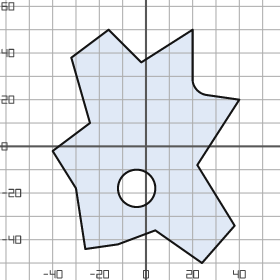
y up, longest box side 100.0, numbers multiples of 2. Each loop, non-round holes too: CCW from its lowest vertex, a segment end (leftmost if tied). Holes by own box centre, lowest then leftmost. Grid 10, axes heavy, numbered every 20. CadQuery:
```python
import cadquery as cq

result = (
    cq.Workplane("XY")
    .moveTo(24.0, -50.0)
    .lineTo(38.0, -34.0)
    .lineTo(22.0, -8.0)
    .lineTo(40.0, 20.0)
    .lineTo(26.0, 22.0)
    .threePointArc((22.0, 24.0), (20.0, 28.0))
    .lineTo(20.0, 50.0)
    .lineTo(-2.0, 36.0)
    .lineTo(-16.0, 50.0)
    .lineTo(-32.0, 38.0)
    .lineTo(-24.0, 10.0)
    .lineTo(-40.0, -2.0)
    .lineTo(-30.0, -18.0)
    .lineTo(-26.0, -44.0)
    .lineTo(-12.0, -42.0)
    .lineTo(4.0, -36.0)
    .close()
    .moveTo(-4.0, -18.0)
    .circle(8.0)
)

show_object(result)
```